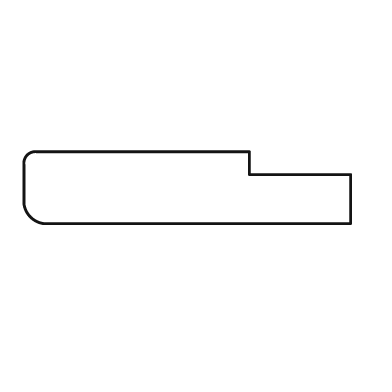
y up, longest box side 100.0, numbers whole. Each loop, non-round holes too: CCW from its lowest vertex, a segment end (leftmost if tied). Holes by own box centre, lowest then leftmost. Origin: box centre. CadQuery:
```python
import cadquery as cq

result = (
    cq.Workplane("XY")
    .moveTo(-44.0, -11.0)
    .lineTo(50.0, -11.0)
    .lineTo(50.0, 4.0)
    .lineTo(19.0, 4.0)
    .lineTo(19.0, 11.0)
    .lineTo(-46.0, 11.0)
    .threePointArc((-49.0, 10.0), (-50.0, 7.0))
    .lineTo(-50.0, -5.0)
    .threePointArc((-48.0, -9.0), (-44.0, -11.0))
    .close()
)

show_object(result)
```